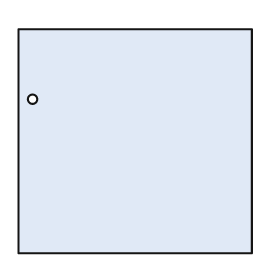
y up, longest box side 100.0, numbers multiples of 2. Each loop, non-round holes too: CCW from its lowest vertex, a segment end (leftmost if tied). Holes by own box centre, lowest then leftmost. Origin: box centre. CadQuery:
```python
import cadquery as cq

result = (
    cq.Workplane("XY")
    .moveTo(-50.0, -48.0)
    .lineTo(50.0, -48.0)
    .lineTo(50.0, 48.0)
    .lineTo(-50.0, 48.0)
    .close()
    .moveTo(-44.0, 18.0)
    .circle(2.0)
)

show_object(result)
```